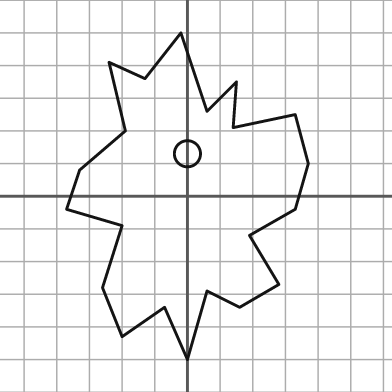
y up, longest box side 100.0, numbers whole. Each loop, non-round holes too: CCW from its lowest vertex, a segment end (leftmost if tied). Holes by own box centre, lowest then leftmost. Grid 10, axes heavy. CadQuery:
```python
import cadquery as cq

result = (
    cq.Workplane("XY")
    .moveTo(0.0, -50.0)
    .lineTo(6.0, -29.0)
    .lineTo(16.0, -34.0)
    .lineTo(28.0, -27.0)
    .lineTo(19.0, -12.0)
    .lineTo(33.0, -4.0)
    .lineTo(37.0, 10.0)
    .lineTo(33.0, 25.0)
    .lineTo(14.0, 21.0)
    .lineTo(15.0, 35.0)
    .lineTo(6.0, 26.0)
    .lineTo(-2.0, 50.0)
    .lineTo(-13.0, 36.0)
    .lineTo(-24.0, 41.0)
    .lineTo(-19.0, 20.0)
    .lineTo(-33.0, 8.0)
    .lineTo(-37.0, -4.0)
    .lineTo(-20.0, -9.0)
    .lineTo(-26.0, -28.0)
    .lineTo(-20.0, -43.0)
    .lineTo(-7.0, -34.0)
    .close()
    .moveTo(0.0, 13.0)
    .circle(4.0)
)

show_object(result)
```